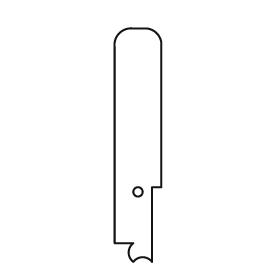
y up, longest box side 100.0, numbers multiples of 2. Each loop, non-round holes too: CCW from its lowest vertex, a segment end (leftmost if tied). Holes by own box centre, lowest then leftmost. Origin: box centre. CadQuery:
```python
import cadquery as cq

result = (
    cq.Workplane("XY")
    .moveTo(-2.0, -50.0)
    .threePointArc((2.0, -48.0), (6.0, -50.0))
    .lineTo(6.0, -18.0)
    .lineTo(10.0, -18.0)
    .lineTo(10.0, 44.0)
    .threePointArc((8.0, 48.0), (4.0, 50.0))
    .lineTo(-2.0, 50.0)
    .threePointArc((-8.0, 48.0), (-10.0, 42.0))
    .lineTo(-10.0, -42.0)
    .lineTo(-2.0, -42.0)
    .threePointArc((-4.0, -46.0), (-2.0, -50.0))
    .close()
    .moveTo(0.0, -20.0)
    .circle(2.0)
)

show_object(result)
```